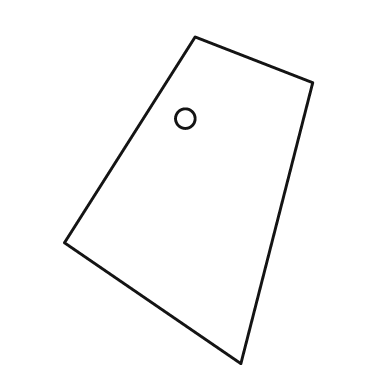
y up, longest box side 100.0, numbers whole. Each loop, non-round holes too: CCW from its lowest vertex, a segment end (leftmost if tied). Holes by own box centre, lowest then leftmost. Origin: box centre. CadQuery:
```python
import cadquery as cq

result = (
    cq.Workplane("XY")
    .moveTo(16.0, -50.0)
    .lineTo(38.0, 36.0)
    .lineTo(2.0, 50.0)
    .lineTo(-38.0, -13.0)
    .close()
    .moveTo(-1.0, 25.0)
    .circle(3.0)
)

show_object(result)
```